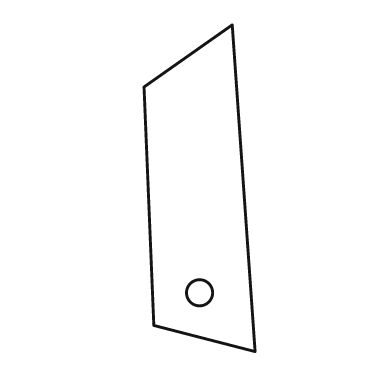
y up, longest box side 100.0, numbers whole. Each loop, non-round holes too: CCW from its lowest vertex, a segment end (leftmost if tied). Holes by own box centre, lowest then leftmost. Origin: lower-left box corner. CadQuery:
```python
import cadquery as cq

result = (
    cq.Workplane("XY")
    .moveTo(34.0, 0.0)
    .lineTo(27.0, 100.0)
    .lineTo(0.0, 81.0)
    .lineTo(3.0, 8.0)
    .close()
    .moveTo(17.0, 18.0)
    .circle(4.0)
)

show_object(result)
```